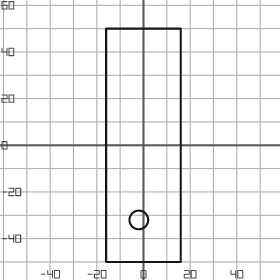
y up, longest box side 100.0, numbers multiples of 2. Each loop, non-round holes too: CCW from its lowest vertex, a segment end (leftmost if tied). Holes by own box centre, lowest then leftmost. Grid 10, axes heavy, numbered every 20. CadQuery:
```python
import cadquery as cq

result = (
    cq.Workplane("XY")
    .moveTo(-16.0, -50.0)
    .lineTo(16.0, -50.0)
    .lineTo(16.0, 50.0)
    .lineTo(-16.0, 50.0)
    .close()
    .moveTo(-2.0, -32.0)
    .circle(4.0)
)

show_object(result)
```